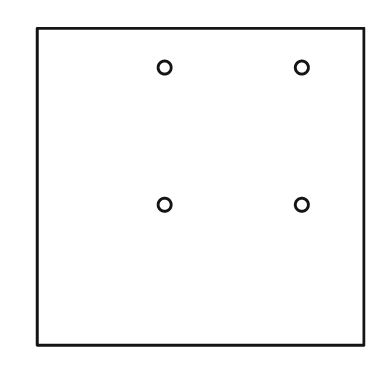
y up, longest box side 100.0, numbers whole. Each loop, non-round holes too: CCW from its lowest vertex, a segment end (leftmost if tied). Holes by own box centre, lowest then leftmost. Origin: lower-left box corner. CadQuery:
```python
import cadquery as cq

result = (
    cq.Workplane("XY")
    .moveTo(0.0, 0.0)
    .lineTo(100.0, 0.0)
    .lineTo(100.0, 97.0)
    .lineTo(0.0, 97.0)
    .close()
    .moveTo(39.0, 43.0)
    .circle(2.0)
    .moveTo(81.0, 43.0)
    .circle(2.0)
    .moveTo(39.0, 85.0)
    .circle(2.0)
    .moveTo(81.0, 85.0)
    .circle(2.0)
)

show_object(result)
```